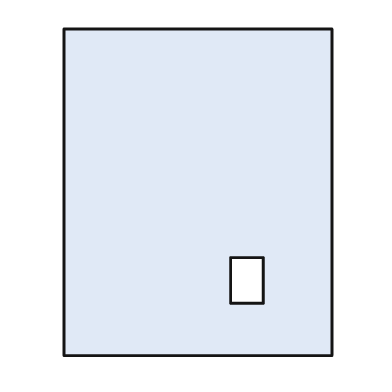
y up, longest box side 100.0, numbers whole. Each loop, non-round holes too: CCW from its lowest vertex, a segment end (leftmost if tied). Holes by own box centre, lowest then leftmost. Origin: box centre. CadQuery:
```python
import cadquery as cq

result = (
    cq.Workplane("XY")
    .moveTo(-41.0, -50.0)
    .lineTo(41.0, -50.0)
    .lineTo(41.0, 50.0)
    .lineTo(-41.0, 50.0)
    .close()
    .moveTo(10.0, -34.0)
    .lineTo(20.0, -34.0)
    .lineTo(20.0, -20.0)
    .lineTo(10.0, -20.0)
    .close()
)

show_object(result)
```